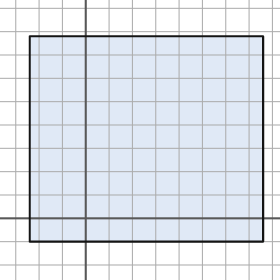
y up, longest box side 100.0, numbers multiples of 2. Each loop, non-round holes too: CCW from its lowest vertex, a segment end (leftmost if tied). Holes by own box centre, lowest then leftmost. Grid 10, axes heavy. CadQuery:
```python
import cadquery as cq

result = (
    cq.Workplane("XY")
    .moveTo(-24.0, -10.0)
    .lineTo(76.0, -10.0)
    .lineTo(76.0, 78.0)
    .lineTo(-24.0, 78.0)
    .close()
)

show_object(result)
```